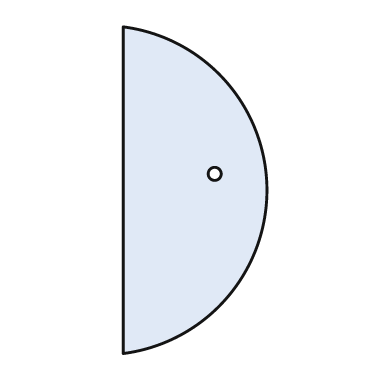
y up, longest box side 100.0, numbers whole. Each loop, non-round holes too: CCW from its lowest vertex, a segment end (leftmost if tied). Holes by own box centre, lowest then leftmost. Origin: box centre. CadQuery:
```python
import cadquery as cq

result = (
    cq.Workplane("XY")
    .moveTo(-22.0, -50.0)
    .threePointArc((22.0, 0.0), (-22.0, 50.0))
    .close()
    .moveTo(6.0, 5.0)
    .circle(2.0)
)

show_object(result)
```